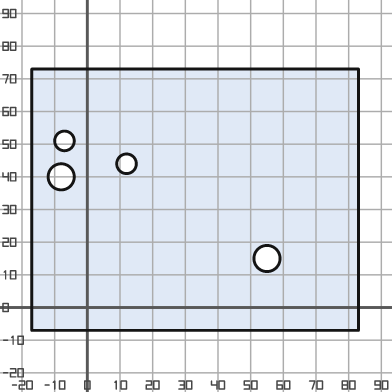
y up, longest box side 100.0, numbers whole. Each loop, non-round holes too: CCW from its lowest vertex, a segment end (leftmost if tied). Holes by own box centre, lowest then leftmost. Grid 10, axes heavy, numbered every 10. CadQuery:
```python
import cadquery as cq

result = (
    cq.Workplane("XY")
    .moveTo(-17.0, -7.0)
    .lineTo(83.0, -7.0)
    .lineTo(83.0, 73.0)
    .lineTo(-17.0, 73.0)
    .close()
    .moveTo(55.0, 15.0)
    .circle(4.0)
    .moveTo(-8.0, 40.0)
    .circle(4.0)
    .moveTo(12.0, 44.0)
    .circle(3.0)
    .moveTo(-7.0, 51.0)
    .circle(3.0)
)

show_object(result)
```